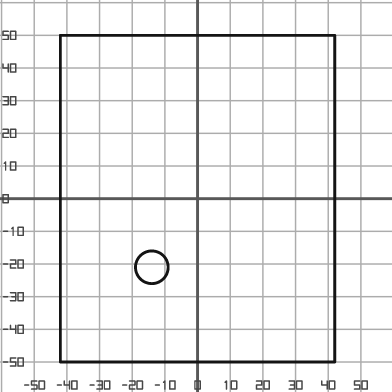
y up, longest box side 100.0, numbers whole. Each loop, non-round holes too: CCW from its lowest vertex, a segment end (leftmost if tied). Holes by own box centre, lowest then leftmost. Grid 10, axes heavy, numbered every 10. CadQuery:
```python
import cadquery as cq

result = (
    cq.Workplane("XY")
    .moveTo(-42.0, -50.0)
    .lineTo(42.0, -50.0)
    .lineTo(42.0, 50.0)
    .lineTo(-42.0, 50.0)
    .close()
    .moveTo(-14.0, -21.0)
    .circle(5.0)
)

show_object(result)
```